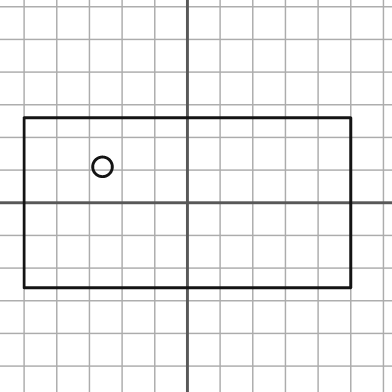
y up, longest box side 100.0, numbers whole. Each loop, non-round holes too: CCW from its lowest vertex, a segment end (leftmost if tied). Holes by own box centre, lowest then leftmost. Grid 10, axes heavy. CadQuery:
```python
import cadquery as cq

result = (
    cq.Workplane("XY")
    .moveTo(-50.0, -26.0)
    .lineTo(50.0, -26.0)
    .lineTo(50.0, 26.0)
    .lineTo(-50.0, 26.0)
    .close()
    .moveTo(-26.0, 11.0)
    .circle(3.0)
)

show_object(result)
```